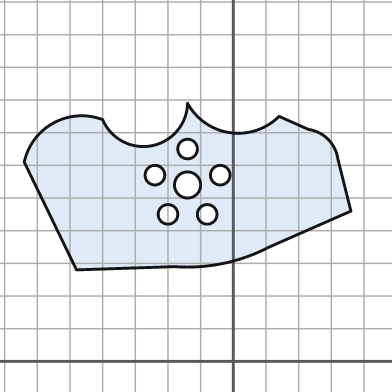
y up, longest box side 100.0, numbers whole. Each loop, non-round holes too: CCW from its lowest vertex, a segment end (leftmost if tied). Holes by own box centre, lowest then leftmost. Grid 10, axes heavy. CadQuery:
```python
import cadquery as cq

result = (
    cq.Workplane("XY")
    .moveTo(-48.0, 28.0)
    .lineTo(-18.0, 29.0)
    .threePointArc((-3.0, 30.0), (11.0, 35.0))
    .lineTo(36.0, 46.0)
    .lineTo(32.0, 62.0)
    .threePointArc((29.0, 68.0), (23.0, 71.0))
    .lineTo(14.0, 75.0)
    .threePointArc((-1.0, 70.0), (-14.0, 79.0))
    .threePointArc((-25.0, 66.0), (-40.0, 74.0))
    .threePointArc((-55.0, 73.0), (-64.0, 61.0))
    .close()
    .moveTo(-20.0, 45.0)
    .circle(3.0)
    .moveTo(-8.0, 45.0)
    .circle(3.0)
    .moveTo(-14.0, 54.0)
    .circle(4.0)
    .moveTo(-24.0, 57.0)
    .circle(3.0)
    .moveTo(-4.0, 57.0)
    .circle(3.0)
    .moveTo(-14.0, 65.0)
    .circle(3.0)
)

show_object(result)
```